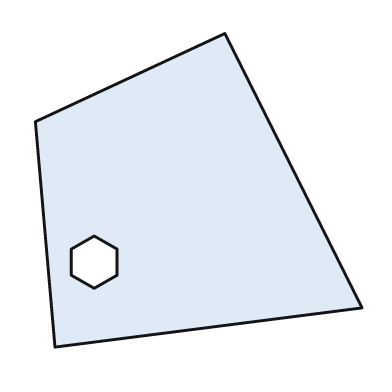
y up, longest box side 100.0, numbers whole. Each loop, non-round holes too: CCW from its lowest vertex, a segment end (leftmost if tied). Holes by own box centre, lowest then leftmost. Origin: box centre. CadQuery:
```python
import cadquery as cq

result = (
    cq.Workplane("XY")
    .moveTo(-44.0, -48.0)
    .lineTo(50.0, -36.0)
    .lineTo(8.0, 48.0)
    .lineTo(-50.0, 21.0)
    .close()
    .moveTo(-32.0, -30.0)
    .lineTo(-25.0, -26.0)
    .lineTo(-25.0, -18.0)
    .lineTo(-32.0, -14.0)
    .lineTo(-39.0, -18.0)
    .lineTo(-39.0, -26.0)
    .close()
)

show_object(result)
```